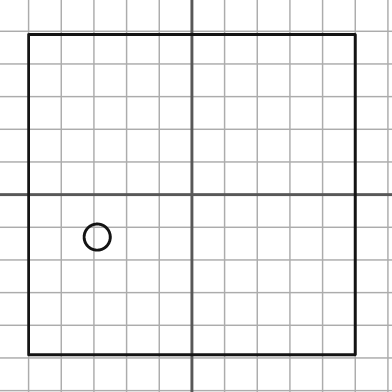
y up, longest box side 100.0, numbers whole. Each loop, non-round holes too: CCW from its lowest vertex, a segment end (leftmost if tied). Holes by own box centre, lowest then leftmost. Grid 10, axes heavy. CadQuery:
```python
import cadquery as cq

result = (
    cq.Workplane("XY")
    .moveTo(-50.0, -49.0)
    .lineTo(50.0, -49.0)
    .lineTo(50.0, 49.0)
    .lineTo(-50.0, 49.0)
    .close()
    .moveTo(-29.0, -13.0)
    .circle(4.0)
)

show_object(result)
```